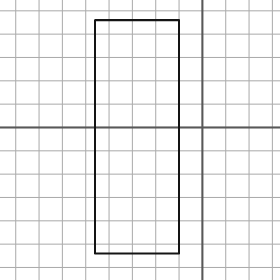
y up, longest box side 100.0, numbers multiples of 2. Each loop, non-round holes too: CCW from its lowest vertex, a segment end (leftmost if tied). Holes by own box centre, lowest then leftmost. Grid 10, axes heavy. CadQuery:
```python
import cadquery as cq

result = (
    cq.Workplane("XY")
    .moveTo(-46.0, -54.0)
    .lineTo(-10.0, -54.0)
    .lineTo(-10.0, 46.0)
    .lineTo(-46.0, 46.0)
    .close()
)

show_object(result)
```